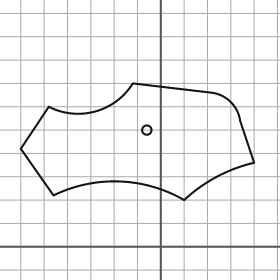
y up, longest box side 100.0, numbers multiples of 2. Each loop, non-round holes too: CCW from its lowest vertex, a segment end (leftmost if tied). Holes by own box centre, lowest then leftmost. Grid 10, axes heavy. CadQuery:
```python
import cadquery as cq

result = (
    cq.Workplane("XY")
    .moveTo(10.0, 20.0)
    .threePointArc((24.0, 30.0), (40.0, 36.0))
    .lineTo(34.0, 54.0)
    .threePointArc((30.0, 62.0), (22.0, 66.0))
    .lineTo(-12.0, 70.0)
    .threePointArc((-28.0, 58.0), (-48.0, 60.0))
    .lineTo(-60.0, 42.0)
    .lineTo(-46.0, 22.0)
    .threePointArc((-18.0, 28.0), (10.0, 20.0))
    .close()
    .moveTo(-6.0, 50.0)
    .circle(2.0)
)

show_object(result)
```